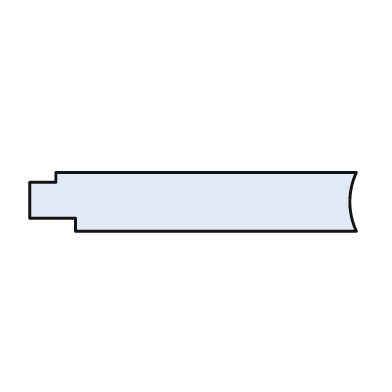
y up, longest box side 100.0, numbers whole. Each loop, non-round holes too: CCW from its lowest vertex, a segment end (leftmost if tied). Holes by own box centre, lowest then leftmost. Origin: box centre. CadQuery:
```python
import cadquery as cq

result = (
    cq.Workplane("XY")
    .moveTo(-36.0, -9.0)
    .lineTo(50.0, -9.0)
    .threePointArc((48.0, 0.0), (50.0, 9.0))
    .lineTo(-42.0, 9.0)
    .lineTo(-42.0, 6.0)
    .lineTo(-50.0, 6.0)
    .lineTo(-50.0, -5.0)
    .lineTo(-36.0, -5.0)
    .close()
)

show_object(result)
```